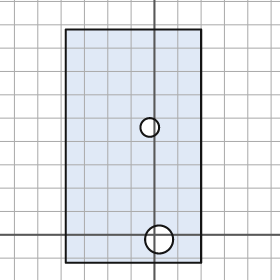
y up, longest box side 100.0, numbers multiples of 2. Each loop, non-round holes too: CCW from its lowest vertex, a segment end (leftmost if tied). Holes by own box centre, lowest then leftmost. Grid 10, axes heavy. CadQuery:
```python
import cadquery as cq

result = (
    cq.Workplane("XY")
    .moveTo(-38.0, -12.0)
    .lineTo(20.0, -12.0)
    .lineTo(20.0, 88.0)
    .lineTo(-38.0, 88.0)
    .close()
    .moveTo(2.0, -2.0)
    .circle(6.0)
    .moveTo(-2.0, 46.0)
    .circle(4.0)
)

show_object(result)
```